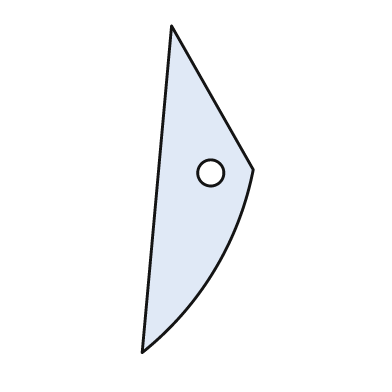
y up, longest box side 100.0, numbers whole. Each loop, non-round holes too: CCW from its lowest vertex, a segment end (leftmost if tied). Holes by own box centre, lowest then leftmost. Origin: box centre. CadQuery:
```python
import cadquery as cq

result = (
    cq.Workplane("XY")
    .moveTo(-17.0, -50.0)
    .threePointArc((5.0, -25.0), (17.0, 6.0))
    .lineTo(-8.0, 50.0)
    .close()
    .moveTo(4.0, 5.0)
    .circle(4.0)
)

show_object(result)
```